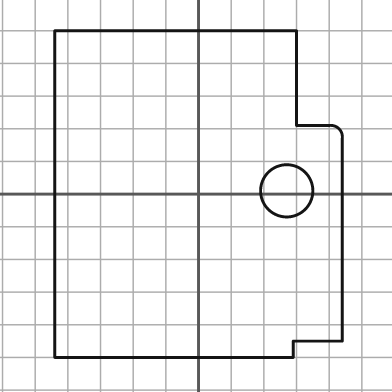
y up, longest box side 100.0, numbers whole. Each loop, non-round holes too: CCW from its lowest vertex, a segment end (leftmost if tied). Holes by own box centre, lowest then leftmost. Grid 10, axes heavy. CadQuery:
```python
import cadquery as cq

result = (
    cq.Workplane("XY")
    .moveTo(-44.0, -50.0)
    .lineTo(29.0, -50.0)
    .lineTo(29.0, -45.0)
    .lineTo(44.0, -45.0)
    .lineTo(44.0, 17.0)
    .threePointArc((43.0, 20.0), (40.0, 21.0))
    .lineTo(30.0, 21.0)
    .lineTo(30.0, 50.0)
    .lineTo(-44.0, 50.0)
    .close()
    .moveTo(27.0, 1.0)
    .circle(8.0)
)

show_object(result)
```